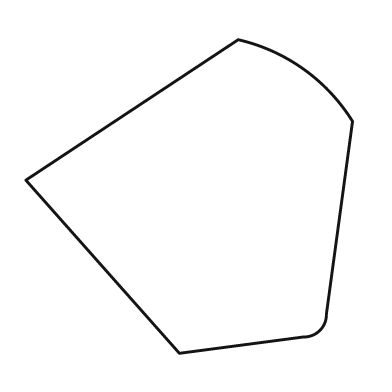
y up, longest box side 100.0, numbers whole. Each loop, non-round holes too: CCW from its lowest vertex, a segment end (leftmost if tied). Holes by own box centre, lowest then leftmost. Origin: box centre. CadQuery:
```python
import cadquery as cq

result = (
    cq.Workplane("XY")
    .moveTo(-3.0, -48.0)
    .lineTo(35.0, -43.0)
    .threePointArc((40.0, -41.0), (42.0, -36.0))
    .lineTo(50.0, 23.0)
    .threePointArc((35.0, 39.0), (15.0, 48.0))
    .lineTo(-50.0, 5.0)
    .close()
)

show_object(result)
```